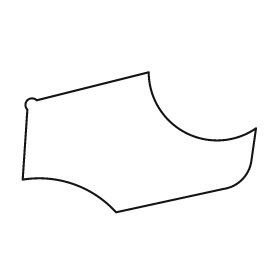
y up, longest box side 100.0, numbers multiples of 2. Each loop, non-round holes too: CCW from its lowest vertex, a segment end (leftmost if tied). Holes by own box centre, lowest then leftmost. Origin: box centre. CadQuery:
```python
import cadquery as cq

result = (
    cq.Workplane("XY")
    .moveTo(-10.0, -30.0)
    .lineTo(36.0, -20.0)
    .threePointArc((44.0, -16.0), (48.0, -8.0))
    .lineTo(50.0, 6.0)
    .threePointArc((20.0, 4.0), (4.0, 30.0))
    .lineTo(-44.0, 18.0)
    .threePointArc((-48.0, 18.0), (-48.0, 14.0))
    .lineTo(-50.0, -16.0)
    .threePointArc((-28.0, -18.0), (-10.0, -30.0))
    .close()
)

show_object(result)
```